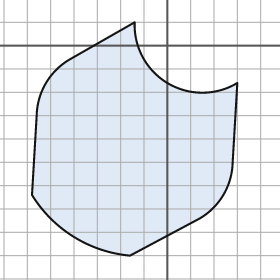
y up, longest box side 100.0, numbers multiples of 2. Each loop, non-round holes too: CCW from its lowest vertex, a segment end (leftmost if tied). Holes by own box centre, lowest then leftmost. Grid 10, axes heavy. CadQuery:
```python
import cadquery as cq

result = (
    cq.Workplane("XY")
    .moveTo(-16.0, -90.0)
    .lineTo(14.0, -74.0)
    .threePointArc((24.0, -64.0), (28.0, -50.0))
    .lineTo(30.0, -16.0)
    .threePointArc((0.0, -16.0), (-14.0, 10.0))
    .lineTo(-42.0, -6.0)
    .threePointArc((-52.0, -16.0), (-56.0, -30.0))
    .lineTo(-58.0, -64.0)
    .threePointArc((-40.0, -82.0), (-16.0, -90.0))
    .close()
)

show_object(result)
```